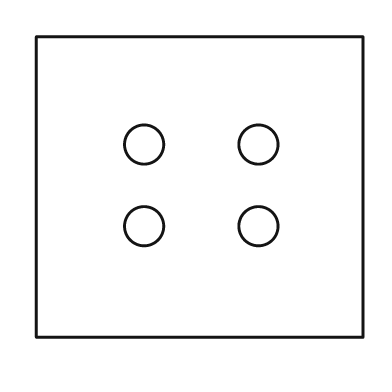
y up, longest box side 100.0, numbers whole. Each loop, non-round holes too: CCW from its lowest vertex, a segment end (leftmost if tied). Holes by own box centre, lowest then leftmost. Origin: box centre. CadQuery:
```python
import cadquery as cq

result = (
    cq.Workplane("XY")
    .moveTo(-50.0, -46.0)
    .lineTo(50.0, -46.0)
    .lineTo(50.0, 46.0)
    .lineTo(-50.0, 46.0)
    .close()
    .moveTo(-17.0, -12.0)
    .circle(6.0)
    .moveTo(18.0, -12.0)
    .circle(6.0)
    .moveTo(-17.0, 13.0)
    .circle(6.0)
    .moveTo(18.0, 13.0)
    .circle(6.0)
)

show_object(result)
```